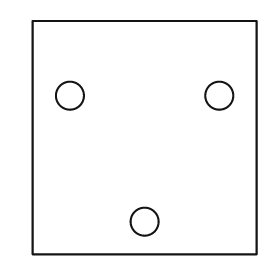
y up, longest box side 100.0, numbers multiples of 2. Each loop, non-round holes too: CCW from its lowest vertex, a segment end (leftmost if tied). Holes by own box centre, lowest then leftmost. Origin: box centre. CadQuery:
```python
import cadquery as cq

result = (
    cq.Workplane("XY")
    .moveTo(-48.0, -50.0)
    .lineTo(48.0, -50.0)
    .lineTo(48.0, 50.0)
    .lineTo(-48.0, 50.0)
    .close()
    .moveTo(0.0, -36.0)
    .circle(6.0)
    .moveTo(-32.0, 18.0)
    .circle(6.0)
    .moveTo(32.0, 18.0)
    .circle(6.0)
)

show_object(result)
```